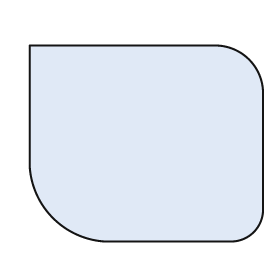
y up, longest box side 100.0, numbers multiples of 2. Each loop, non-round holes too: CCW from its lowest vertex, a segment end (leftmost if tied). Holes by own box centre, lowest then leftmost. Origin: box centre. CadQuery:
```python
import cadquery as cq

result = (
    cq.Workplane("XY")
    .moveTo(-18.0, -42.0)
    .lineTo(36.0, -42.0)
    .threePointArc((46.0, -38.0), (50.0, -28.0))
    .lineTo(50.0, 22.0)
    .threePointArc((44.0, 36.0), (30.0, 42.0))
    .lineTo(-50.0, 42.0)
    .lineTo(-50.0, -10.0)
    .threePointArc((-40.0, -32.0), (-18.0, -42.0))
    .close()
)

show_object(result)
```